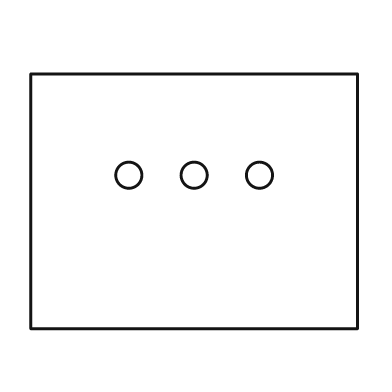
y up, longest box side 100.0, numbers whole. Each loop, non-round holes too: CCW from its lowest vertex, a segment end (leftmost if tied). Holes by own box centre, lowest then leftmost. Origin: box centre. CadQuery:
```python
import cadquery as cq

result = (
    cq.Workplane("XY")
    .moveTo(-50.0, -39.0)
    .lineTo(50.0, -39.0)
    .lineTo(50.0, 39.0)
    .lineTo(-50.0, 39.0)
    .close()
    .moveTo(-20.0, 8.0)
    .circle(4.0)
    .moveTo(0.0, 8.0)
    .circle(4.0)
    .moveTo(20.0, 8.0)
    .circle(4.0)
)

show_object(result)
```